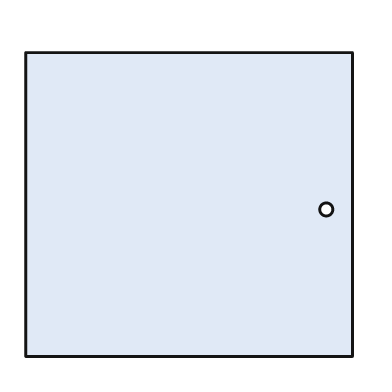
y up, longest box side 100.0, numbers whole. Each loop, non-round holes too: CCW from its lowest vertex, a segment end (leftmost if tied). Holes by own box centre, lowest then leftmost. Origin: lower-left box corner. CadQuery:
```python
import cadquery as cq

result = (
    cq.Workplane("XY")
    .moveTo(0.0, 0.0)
    .lineTo(100.0, 0.0)
    .lineTo(100.0, 93.0)
    .lineTo(0.0, 93.0)
    .close()
    .moveTo(92.0, 45.0)
    .circle(2.0)
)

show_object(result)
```